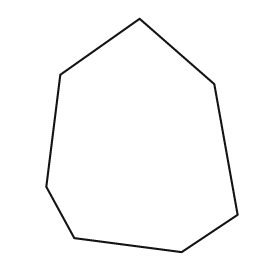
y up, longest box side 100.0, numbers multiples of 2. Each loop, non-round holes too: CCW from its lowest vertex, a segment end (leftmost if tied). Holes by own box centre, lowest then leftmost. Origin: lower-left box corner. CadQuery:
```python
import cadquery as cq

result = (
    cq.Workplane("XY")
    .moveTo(58.0, 0.0)
    .lineTo(82.0, 16.0)
    .lineTo(72.0, 72.0)
    .lineTo(40.0, 100.0)
    .lineTo(6.0, 76.0)
    .lineTo(0.0, 28.0)
    .lineTo(12.0, 6.0)
    .close()
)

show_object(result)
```